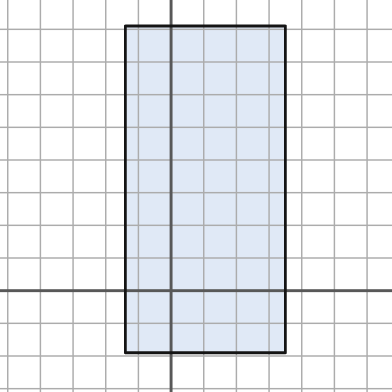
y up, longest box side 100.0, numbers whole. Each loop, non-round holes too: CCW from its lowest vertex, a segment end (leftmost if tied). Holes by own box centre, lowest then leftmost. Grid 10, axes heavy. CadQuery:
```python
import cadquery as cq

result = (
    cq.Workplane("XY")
    .moveTo(-14.0, -19.0)
    .lineTo(35.0, -19.0)
    .lineTo(35.0, 81.0)
    .lineTo(-14.0, 81.0)
    .close()
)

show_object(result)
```